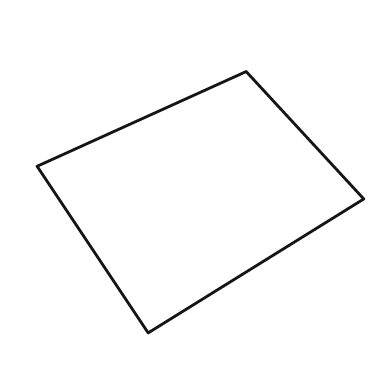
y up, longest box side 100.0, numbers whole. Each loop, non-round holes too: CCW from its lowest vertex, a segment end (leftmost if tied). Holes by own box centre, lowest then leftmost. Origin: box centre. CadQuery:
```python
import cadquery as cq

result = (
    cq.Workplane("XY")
    .moveTo(-16.0, -40.0)
    .lineTo(50.0, 1.0)
    .lineTo(14.0, 40.0)
    .lineTo(-50.0, 11.0)
    .close()
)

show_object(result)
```